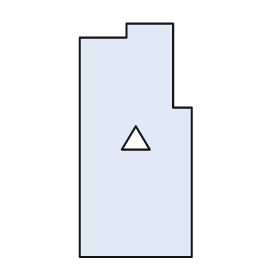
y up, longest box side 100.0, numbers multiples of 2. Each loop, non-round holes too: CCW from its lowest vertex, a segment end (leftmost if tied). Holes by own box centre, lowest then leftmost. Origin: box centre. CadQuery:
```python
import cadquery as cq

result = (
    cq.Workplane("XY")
    .moveTo(-24.0, -50.0)
    .lineTo(24.0, -50.0)
    .lineTo(24.0, 14.0)
    .lineTo(16.0, 14.0)
    .lineTo(16.0, 50.0)
    .lineTo(-4.0, 50.0)
    .lineTo(-4.0, 44.0)
    .lineTo(-24.0, 44.0)
    .close()
    .moveTo(-6.0, -4.0)
    .lineTo(6.0, -4.0)
    .lineTo(0.0, 6.0)
    .close()
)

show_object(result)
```